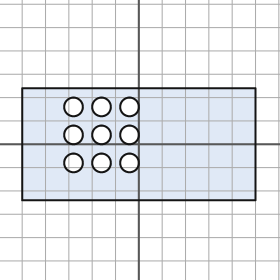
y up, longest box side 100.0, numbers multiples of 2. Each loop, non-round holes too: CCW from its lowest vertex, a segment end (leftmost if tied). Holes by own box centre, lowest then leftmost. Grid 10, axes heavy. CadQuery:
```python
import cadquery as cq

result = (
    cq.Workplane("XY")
    .moveTo(-50.0, -24.0)
    .lineTo(50.0, -24.0)
    .lineTo(50.0, 24.0)
    .lineTo(-50.0, 24.0)
    .close()
    .moveTo(-28.0, -8.0)
    .circle(4.0)
    .moveTo(-16.0, -8.0)
    .circle(4.0)
    .moveTo(-4.0, -8.0)
    .circle(4.0)
    .moveTo(-28.0, 4.0)
    .circle(4.0)
    .moveTo(-16.0, 4.0)
    .circle(4.0)
    .moveTo(-4.0, 4.0)
    .circle(4.0)
    .moveTo(-28.0, 16.0)
    .circle(4.0)
    .moveTo(-16.0, 16.0)
    .circle(4.0)
    .moveTo(-4.0, 16.0)
    .circle(4.0)
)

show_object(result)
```